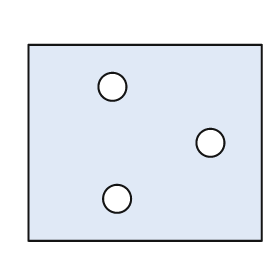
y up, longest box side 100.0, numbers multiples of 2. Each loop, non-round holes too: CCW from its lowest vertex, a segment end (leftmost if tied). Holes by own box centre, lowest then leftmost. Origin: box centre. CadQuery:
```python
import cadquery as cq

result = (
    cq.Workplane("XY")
    .moveTo(-50.0, -42.0)
    .lineTo(50.0, -42.0)
    .lineTo(50.0, 42.0)
    .lineTo(-50.0, 42.0)
    .close()
    .moveTo(-12.0, -24.0)
    .circle(6.0)
    .moveTo(28.0, 0.0)
    .circle(6.0)
    .moveTo(-14.0, 24.0)
    .circle(6.0)
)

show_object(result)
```